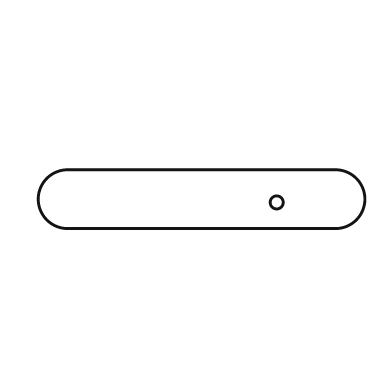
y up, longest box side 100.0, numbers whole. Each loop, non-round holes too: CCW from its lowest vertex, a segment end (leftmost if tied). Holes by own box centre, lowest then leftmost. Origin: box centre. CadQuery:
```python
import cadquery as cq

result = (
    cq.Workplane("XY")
    .moveTo(-41.0, -9.0)
    .lineTo(41.0, -9.0)
    .threePointArc((50.0, 0.0), (41.0, 9.0))
    .lineTo(-41.0, 9.0)
    .threePointArc((-50.0, 0.0), (-41.0, -9.0))
    .close()
    .moveTo(23.0, -1.0)
    .circle(2.0)
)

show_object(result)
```